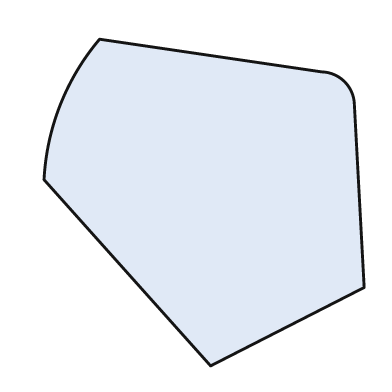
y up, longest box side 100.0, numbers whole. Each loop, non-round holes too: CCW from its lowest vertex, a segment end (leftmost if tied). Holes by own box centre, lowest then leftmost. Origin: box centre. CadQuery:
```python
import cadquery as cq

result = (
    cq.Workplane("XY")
    .moveTo(2.0, -50.0)
    .lineTo(49.0, -26.0)
    .lineTo(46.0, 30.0)
    .threePointArc((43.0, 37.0), (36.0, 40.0))
    .lineTo(-32.0, 50.0)
    .threePointArc((-44.0, 30.0), (-49.0, 7.0))
    .close()
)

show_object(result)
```